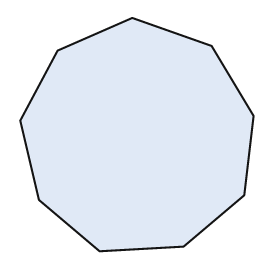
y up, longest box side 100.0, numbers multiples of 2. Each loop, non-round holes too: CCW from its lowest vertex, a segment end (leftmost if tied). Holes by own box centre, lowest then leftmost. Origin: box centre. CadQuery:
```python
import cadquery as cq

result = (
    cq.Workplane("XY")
    .moveTo(-16.0, -50.0)
    .lineTo(20.0, -48.0)
    .lineTo(46.0, -26.0)
    .lineTo(50.0, 8.0)
    .lineTo(32.0, 38.0)
    .lineTo(-2.0, 50.0)
    .lineTo(-34.0, 36.0)
    .lineTo(-50.0, 6.0)
    .lineTo(-42.0, -28.0)
    .close()
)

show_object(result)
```